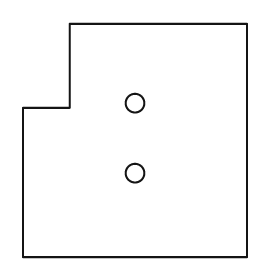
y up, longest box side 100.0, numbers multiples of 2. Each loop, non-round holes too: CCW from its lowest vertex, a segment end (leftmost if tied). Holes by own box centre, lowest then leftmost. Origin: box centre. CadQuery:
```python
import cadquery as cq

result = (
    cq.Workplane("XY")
    .moveTo(-48.0, -50.0)
    .lineTo(48.0, -50.0)
    .lineTo(48.0, 50.0)
    .lineTo(-28.0, 50.0)
    .lineTo(-28.0, 14.0)
    .lineTo(-48.0, 14.0)
    .close()
    .moveTo(0.0, -14.0)
    .circle(4.0)
    .moveTo(0.0, 16.0)
    .circle(4.0)
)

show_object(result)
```